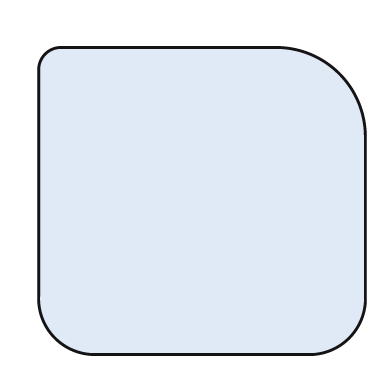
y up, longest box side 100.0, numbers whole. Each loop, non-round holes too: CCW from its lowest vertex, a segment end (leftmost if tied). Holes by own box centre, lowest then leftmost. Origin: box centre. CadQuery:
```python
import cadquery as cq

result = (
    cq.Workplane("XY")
    .moveTo(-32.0, -47.0)
    .lineTo(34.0, -47.0)
    .threePointArc((45.0, -42.0), (50.0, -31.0))
    .lineTo(50.0, 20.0)
    .threePointArc((42.0, 39.0), (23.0, 47.0))
    .lineTo(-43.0, 47.0)
    .threePointArc((-48.0, 45.0), (-50.0, 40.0))
    .lineTo(-50.0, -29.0)
    .threePointArc((-45.0, -42.0), (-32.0, -47.0))
    .close()
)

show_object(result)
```